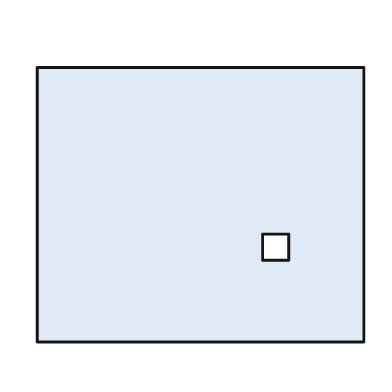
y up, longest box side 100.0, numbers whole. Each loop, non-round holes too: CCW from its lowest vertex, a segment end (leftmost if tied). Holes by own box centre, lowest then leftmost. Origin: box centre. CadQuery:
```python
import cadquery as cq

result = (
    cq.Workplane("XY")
    .moveTo(-50.0, -42.0)
    .lineTo(50.0, -42.0)
    .lineTo(50.0, 42.0)
    .lineTo(-50.0, 42.0)
    .close()
    .moveTo(19.0, -17.0)
    .lineTo(27.0, -17.0)
    .lineTo(27.0, -9.0)
    .lineTo(19.0, -9.0)
    .close()
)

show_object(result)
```